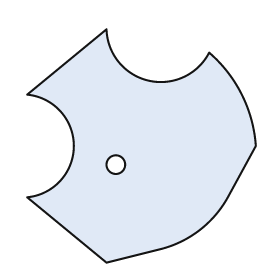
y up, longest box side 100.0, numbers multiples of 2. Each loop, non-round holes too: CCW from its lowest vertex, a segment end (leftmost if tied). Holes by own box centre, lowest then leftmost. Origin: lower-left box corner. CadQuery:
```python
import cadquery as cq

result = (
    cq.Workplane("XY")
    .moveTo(34.0, 0.0)
    .lineTo(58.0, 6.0)
    .threePointArc((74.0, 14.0), (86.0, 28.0))
    .lineTo(98.0, 50.0)
    .threePointArc((92.0, 72.0), (78.0, 90.0))
    .threePointArc((52.0, 78.0), (34.0, 100.0))
    .lineTo(0.0, 72.0)
    .threePointArc((20.0, 50.0), (0.0, 28.0))
    .close()
    .moveTo(38.0, 42.0)
    .circle(4.0)
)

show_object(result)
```